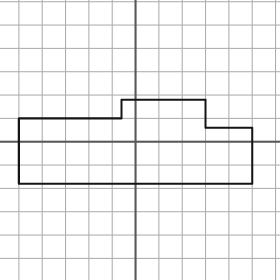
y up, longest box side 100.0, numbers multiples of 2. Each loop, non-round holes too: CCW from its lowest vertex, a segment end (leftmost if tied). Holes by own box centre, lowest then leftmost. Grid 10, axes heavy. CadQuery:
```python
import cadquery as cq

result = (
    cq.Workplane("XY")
    .moveTo(-50.0, -18.0)
    .lineTo(50.0, -18.0)
    .lineTo(50.0, 6.0)
    .lineTo(30.0, 6.0)
    .lineTo(30.0, 18.0)
    .lineTo(-6.0, 18.0)
    .lineTo(-6.0, 10.0)
    .lineTo(-50.0, 10.0)
    .close()
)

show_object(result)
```